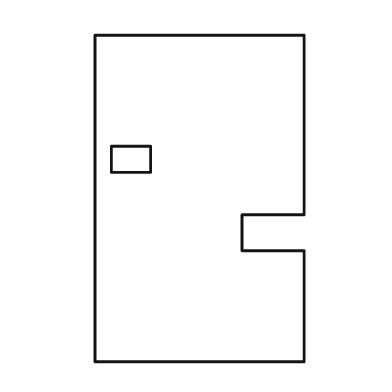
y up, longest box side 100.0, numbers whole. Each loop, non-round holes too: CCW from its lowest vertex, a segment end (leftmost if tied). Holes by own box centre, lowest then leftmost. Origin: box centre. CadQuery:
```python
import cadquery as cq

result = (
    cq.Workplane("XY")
    .moveTo(-32.0, -50.0)
    .lineTo(32.0, -50.0)
    .lineTo(32.0, -16.0)
    .lineTo(13.0, -16.0)
    .lineTo(13.0, -5.0)
    .lineTo(32.0, -5.0)
    .lineTo(32.0, 50.0)
    .lineTo(-32.0, 50.0)
    .close()
    .moveTo(-27.0, 8.0)
    .lineTo(-15.0, 8.0)
    .lineTo(-15.0, 16.0)
    .lineTo(-27.0, 16.0)
    .close()
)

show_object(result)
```